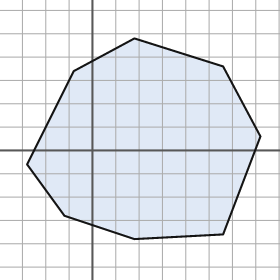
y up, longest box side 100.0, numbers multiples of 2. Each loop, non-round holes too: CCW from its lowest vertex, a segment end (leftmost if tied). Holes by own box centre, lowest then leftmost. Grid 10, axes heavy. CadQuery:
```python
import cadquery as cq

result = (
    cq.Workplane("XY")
    .moveTo(18.0, -38.0)
    .lineTo(56.0, -36.0)
    .lineTo(72.0, 6.0)
    .lineTo(56.0, 36.0)
    .lineTo(18.0, 48.0)
    .lineTo(-8.0, 34.0)
    .lineTo(-28.0, -6.0)
    .lineTo(-12.0, -28.0)
    .close()
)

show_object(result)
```